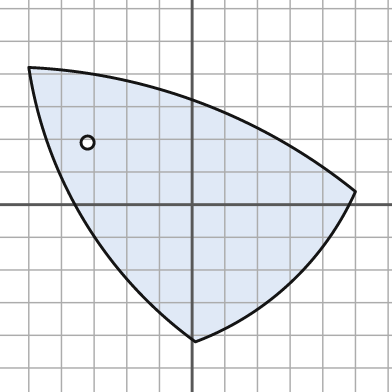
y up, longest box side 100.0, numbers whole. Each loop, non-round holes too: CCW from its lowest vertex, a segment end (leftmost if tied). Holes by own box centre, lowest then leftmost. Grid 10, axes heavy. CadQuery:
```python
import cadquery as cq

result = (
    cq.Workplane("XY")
    .moveTo(1.0, -42.0)
    .threePointArc((30.0, -24.0), (50.0, 4.0))
    .threePointArc((3.0, 31.0), (-50.0, 42.0))
    .threePointArc((-33.0, -5.0), (1.0, -42.0))
    .close()
    .moveTo(-32.0, 19.0)
    .circle(2.0)
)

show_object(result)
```